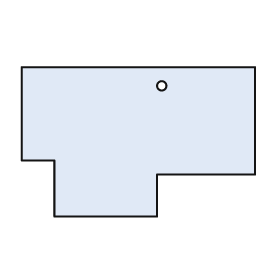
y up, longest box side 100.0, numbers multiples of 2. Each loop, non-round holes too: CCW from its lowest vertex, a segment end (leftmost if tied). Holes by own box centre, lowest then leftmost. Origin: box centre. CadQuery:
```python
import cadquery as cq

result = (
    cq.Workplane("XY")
    .moveTo(-36.0, -32.0)
    .lineTo(8.0, -32.0)
    .lineTo(8.0, -14.0)
    .lineTo(50.0, -14.0)
    .lineTo(50.0, 32.0)
    .lineTo(-50.0, 32.0)
    .lineTo(-50.0, -8.0)
    .lineTo(-36.0, -8.0)
    .close()
    .moveTo(10.0, 24.0)
    .circle(2.0)
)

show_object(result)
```